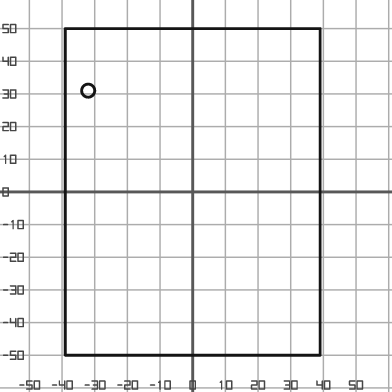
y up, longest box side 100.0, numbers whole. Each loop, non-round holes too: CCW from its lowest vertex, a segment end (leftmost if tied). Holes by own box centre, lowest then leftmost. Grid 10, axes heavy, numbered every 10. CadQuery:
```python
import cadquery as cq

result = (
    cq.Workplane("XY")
    .moveTo(-39.0, -50.0)
    .lineTo(39.0, -50.0)
    .lineTo(39.0, 50.0)
    .lineTo(-39.0, 50.0)
    .close()
    .moveTo(-32.0, 31.0)
    .circle(2.0)
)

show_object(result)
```